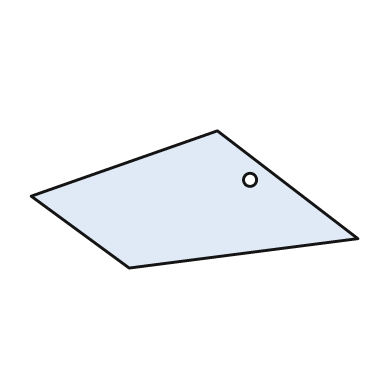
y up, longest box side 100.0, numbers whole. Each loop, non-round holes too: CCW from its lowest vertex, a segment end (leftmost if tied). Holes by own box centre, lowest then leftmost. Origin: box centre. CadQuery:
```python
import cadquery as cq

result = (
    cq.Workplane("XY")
    .moveTo(-20.0, -21.0)
    .lineTo(50.0, -12.0)
    .lineTo(7.0, 21.0)
    .lineTo(-50.0, 1.0)
    .close()
    .moveTo(17.0, 6.0)
    .circle(2.0)
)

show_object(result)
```